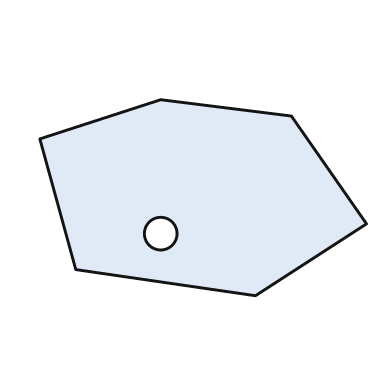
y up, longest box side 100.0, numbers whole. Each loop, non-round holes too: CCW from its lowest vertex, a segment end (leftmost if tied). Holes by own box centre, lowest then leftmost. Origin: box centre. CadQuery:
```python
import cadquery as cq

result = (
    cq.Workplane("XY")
    .moveTo(16.0, -30.0)
    .lineTo(50.0, -8.0)
    .lineTo(27.0, 25.0)
    .lineTo(-13.0, 30.0)
    .lineTo(-50.0, 18.0)
    .lineTo(-39.0, -22.0)
    .close()
    .moveTo(-13.0, -11.0)
    .circle(5.0)
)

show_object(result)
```